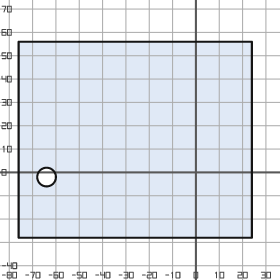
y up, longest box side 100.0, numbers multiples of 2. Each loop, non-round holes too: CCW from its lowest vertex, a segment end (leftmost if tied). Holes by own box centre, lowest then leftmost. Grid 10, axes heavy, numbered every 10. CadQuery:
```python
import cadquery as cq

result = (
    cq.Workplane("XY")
    .moveTo(-76.0, -28.0)
    .lineTo(24.0, -28.0)
    .lineTo(24.0, 56.0)
    .lineTo(-76.0, 56.0)
    .close()
    .moveTo(-64.0, -2.0)
    .circle(4.0)
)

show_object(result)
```